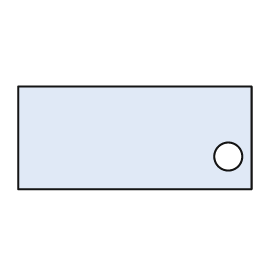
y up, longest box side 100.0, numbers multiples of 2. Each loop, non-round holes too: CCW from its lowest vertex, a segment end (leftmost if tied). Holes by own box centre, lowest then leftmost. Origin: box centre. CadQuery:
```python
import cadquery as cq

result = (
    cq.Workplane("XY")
    .moveTo(-50.0, -22.0)
    .lineTo(50.0, -22.0)
    .lineTo(50.0, 22.0)
    .lineTo(-50.0, 22.0)
    .close()
    .moveTo(40.0, -8.0)
    .circle(6.0)
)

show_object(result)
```